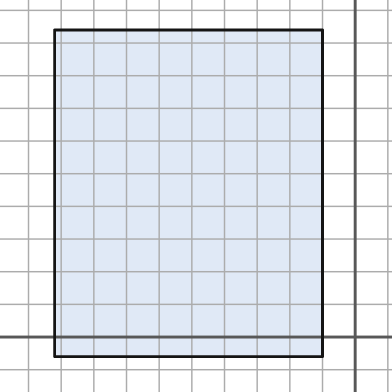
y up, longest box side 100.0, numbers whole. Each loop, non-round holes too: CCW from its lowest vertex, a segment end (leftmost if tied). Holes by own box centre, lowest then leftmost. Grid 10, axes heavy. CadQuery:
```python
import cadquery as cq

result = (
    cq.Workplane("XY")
    .moveTo(-92.0, -6.0)
    .lineTo(-10.0, -6.0)
    .lineTo(-10.0, 94.0)
    .lineTo(-92.0, 94.0)
    .close()
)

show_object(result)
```